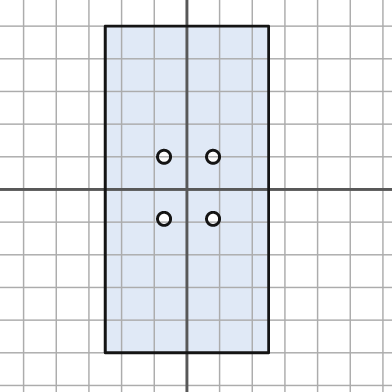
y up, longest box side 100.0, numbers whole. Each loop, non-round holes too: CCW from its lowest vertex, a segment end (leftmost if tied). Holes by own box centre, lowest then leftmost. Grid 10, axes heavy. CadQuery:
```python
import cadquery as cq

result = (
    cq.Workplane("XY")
    .moveTo(-25.0, -50.0)
    .lineTo(25.0, -50.0)
    .lineTo(25.0, 50.0)
    .lineTo(-25.0, 50.0)
    .close()
    .moveTo(-7.0, -9.0)
    .circle(2.0)
    .moveTo(8.0, -9.0)
    .circle(2.0)
    .moveTo(-7.0, 10.0)
    .circle(2.0)
    .moveTo(8.0, 10.0)
    .circle(2.0)
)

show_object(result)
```